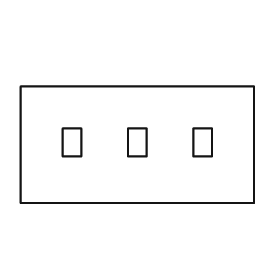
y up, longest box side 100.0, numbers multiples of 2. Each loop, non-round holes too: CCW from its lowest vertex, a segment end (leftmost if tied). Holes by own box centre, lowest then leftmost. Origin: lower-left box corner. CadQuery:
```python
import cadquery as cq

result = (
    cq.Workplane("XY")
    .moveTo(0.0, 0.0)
    .lineTo(100.0, 0.0)
    .lineTo(100.0, 50.0)
    .lineTo(0.0, 50.0)
    .close()
    .moveTo(18.0, 20.0)
    .lineTo(26.0, 20.0)
    .lineTo(26.0, 32.0)
    .lineTo(18.0, 32.0)
    .close()
    .moveTo(46.0, 20.0)
    .lineTo(54.0, 20.0)
    .lineTo(54.0, 32.0)
    .lineTo(46.0, 32.0)
    .close()
    .moveTo(74.0, 20.0)
    .lineTo(82.0, 20.0)
    .lineTo(82.0, 32.0)
    .lineTo(74.0, 32.0)
    .close()
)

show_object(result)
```